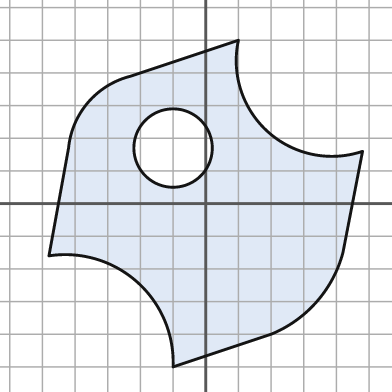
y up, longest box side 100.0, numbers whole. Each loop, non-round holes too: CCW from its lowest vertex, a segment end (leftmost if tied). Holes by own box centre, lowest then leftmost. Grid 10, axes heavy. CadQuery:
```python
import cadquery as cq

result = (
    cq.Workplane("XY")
    .moveTo(-10.0, -50.0)
    .lineTo(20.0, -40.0)
    .threePointArc((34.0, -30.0), (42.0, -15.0))
    .lineTo(48.0, 16.0)
    .threePointArc((19.0, 22.0), (10.0, 50.0))
    .lineTo(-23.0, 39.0)
    .threePointArc((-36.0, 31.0), (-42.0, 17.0))
    .lineTo(-48.0, -16.0)
    .threePointArc((-21.0, -24.0), (-10.0, -50.0))
    .close()
    .moveTo(-10.0, 17.0)
    .circle(12.0)
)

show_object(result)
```